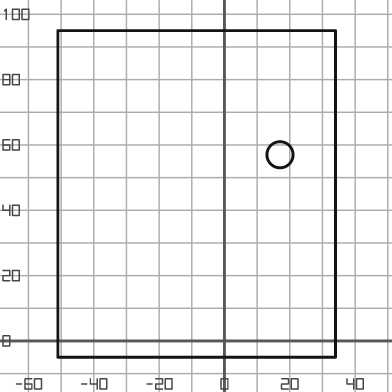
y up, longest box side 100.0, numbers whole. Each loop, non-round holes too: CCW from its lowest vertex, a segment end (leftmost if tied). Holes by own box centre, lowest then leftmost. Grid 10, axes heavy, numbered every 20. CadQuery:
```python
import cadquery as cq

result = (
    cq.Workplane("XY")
    .moveTo(-51.0, -5.0)
    .lineTo(34.0, -5.0)
    .lineTo(34.0, 95.0)
    .lineTo(-51.0, 95.0)
    .close()
    .moveTo(17.0, 57.0)
    .circle(4.0)
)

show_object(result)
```